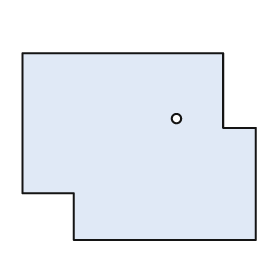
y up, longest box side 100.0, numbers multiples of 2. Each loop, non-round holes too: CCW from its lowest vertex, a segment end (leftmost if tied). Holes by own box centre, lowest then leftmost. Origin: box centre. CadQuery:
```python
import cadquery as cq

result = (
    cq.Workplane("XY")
    .moveTo(-28.0, -40.0)
    .lineTo(50.0, -40.0)
    .lineTo(50.0, 8.0)
    .lineTo(36.0, 8.0)
    .lineTo(36.0, 40.0)
    .lineTo(-50.0, 40.0)
    .lineTo(-50.0, -20.0)
    .lineTo(-28.0, -20.0)
    .close()
    .moveTo(16.0, 12.0)
    .circle(2.0)
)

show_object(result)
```